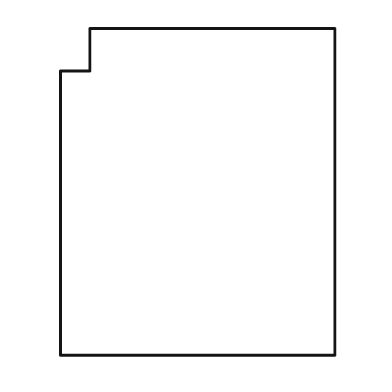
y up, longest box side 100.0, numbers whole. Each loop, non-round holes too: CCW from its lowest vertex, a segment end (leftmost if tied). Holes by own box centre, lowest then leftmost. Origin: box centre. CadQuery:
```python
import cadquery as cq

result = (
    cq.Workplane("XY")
    .moveTo(-42.0, -50.0)
    .lineTo(42.0, -50.0)
    .lineTo(42.0, 50.0)
    .lineTo(-33.0, 50.0)
    .lineTo(-33.0, 37.0)
    .lineTo(-42.0, 37.0)
    .close()
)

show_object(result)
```